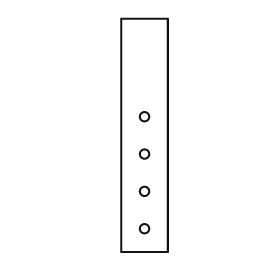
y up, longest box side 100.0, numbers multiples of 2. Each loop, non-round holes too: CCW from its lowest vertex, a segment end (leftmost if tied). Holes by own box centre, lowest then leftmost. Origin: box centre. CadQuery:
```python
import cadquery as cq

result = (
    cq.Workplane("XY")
    .moveTo(-10.0, -50.0)
    .lineTo(10.0, -50.0)
    .lineTo(10.0, 50.0)
    .lineTo(-10.0, 50.0)
    .close()
    .moveTo(0.0, -40.0)
    .circle(2.0)
    .moveTo(0.0, -24.0)
    .circle(2.0)
    .moveTo(0.0, -8.0)
    .circle(2.0)
    .moveTo(0.0, 8.0)
    .circle(2.0)
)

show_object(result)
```